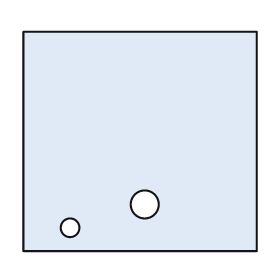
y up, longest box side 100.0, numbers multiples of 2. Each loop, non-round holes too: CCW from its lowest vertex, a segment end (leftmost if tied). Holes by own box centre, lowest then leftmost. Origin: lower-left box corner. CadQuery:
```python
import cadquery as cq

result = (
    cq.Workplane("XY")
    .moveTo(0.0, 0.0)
    .lineTo(100.0, 0.0)
    .lineTo(100.0, 94.0)
    .lineTo(0.0, 94.0)
    .close()
    .moveTo(20.0, 10.0)
    .circle(4.0)
    .moveTo(52.0, 20.0)
    .circle(6.0)
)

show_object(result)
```